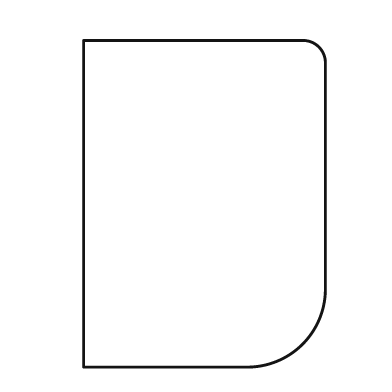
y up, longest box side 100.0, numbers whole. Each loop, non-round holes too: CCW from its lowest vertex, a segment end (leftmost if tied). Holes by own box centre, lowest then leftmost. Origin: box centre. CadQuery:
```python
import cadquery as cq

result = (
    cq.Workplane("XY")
    .moveTo(-37.0, -50.0)
    .lineTo(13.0, -50.0)
    .threePointArc((30.0, -43.0), (37.0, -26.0))
    .lineTo(37.0, 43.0)
    .threePointArc((35.0, 48.0), (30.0, 50.0))
    .lineTo(-37.0, 50.0)
    .close()
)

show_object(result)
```